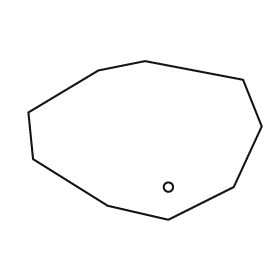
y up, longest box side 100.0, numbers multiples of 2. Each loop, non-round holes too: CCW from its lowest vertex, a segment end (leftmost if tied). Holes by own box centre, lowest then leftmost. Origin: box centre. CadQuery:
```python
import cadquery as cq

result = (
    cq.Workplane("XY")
    .moveTo(10.0, -34.0)
    .lineTo(38.0, -20.0)
    .lineTo(50.0, 6.0)
    .lineTo(42.0, 26.0)
    .lineTo(0.0, 34.0)
    .lineTo(-20.0, 30.0)
    .lineTo(-50.0, 12.0)
    .lineTo(-48.0, -8.0)
    .lineTo(-16.0, -28.0)
    .close()
    .moveTo(10.0, -20.0)
    .circle(2.0)
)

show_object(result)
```